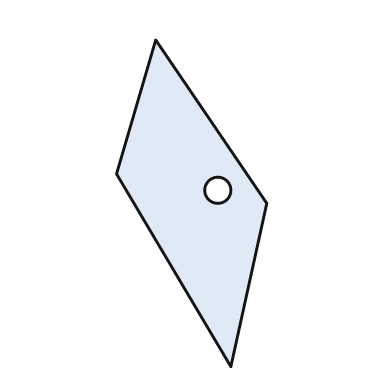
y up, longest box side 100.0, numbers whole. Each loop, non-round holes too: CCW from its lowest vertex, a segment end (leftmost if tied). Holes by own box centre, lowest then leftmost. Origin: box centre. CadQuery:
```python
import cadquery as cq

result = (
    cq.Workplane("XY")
    .moveTo(12.0, -50.0)
    .lineTo(23.0, 0.0)
    .lineTo(-11.0, 50.0)
    .lineTo(-23.0, 9.0)
    .close()
    .moveTo(8.0, 4.0)
    .circle(4.0)
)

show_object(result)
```